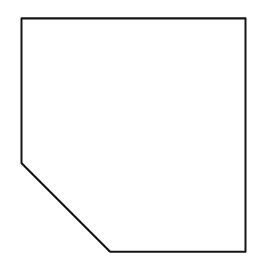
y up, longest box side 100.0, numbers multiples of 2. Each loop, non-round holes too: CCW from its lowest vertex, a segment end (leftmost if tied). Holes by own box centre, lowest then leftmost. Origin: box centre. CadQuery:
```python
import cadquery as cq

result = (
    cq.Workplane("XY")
    .moveTo(-10.0, -50.0)
    .lineTo(48.0, -50.0)
    .lineTo(48.0, 50.0)
    .lineTo(-48.0, 50.0)
    .lineTo(-48.0, -12.0)
    .close()
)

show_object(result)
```